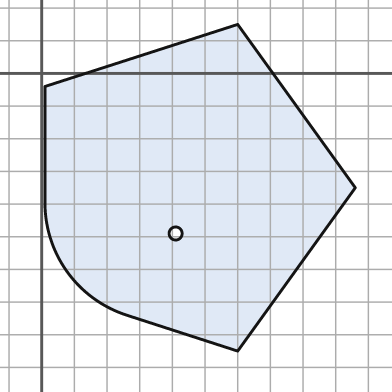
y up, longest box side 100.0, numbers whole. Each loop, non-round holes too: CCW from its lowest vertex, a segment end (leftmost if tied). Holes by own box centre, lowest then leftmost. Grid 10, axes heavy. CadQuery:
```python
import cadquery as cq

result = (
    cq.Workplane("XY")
    .moveTo(60.0, -85.0)
    .lineTo(96.0, -35.0)
    .lineTo(60.0, 15.0)
    .lineTo(1.0, -4.0)
    .lineTo(1.0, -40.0)
    .threePointArc((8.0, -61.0), (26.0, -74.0))
    .close()
    .moveTo(41.0, -49.0)
    .circle(2.0)
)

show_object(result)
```